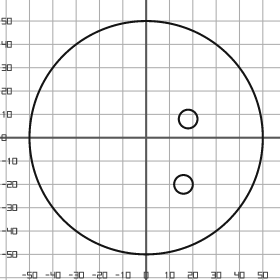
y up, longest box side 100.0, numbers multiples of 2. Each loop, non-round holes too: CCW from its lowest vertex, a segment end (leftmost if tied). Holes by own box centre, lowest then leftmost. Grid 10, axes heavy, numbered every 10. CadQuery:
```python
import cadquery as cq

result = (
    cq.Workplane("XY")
    .moveTo(0.0, 0.0)
    .circle(50.0)
    .moveTo(16.0, -20.0)
    .circle(4.0)
    .moveTo(18.0, 8.0)
    .circle(4.0)
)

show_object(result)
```